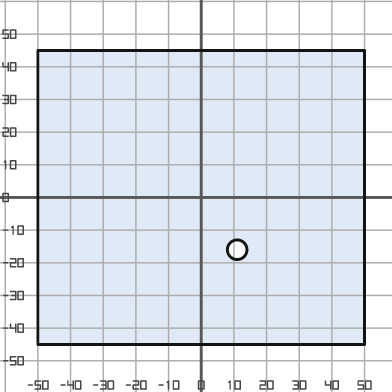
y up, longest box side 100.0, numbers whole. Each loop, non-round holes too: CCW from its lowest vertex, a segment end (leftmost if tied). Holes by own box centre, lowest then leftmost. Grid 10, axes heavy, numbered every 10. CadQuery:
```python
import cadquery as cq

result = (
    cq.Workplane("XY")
    .moveTo(-50.0, -45.0)
    .lineTo(50.0, -45.0)
    .lineTo(50.0, 45.0)
    .lineTo(-50.0, 45.0)
    .close()
    .moveTo(11.0, -16.0)
    .circle(3.0)
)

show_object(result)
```